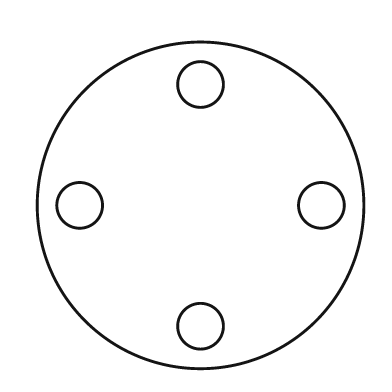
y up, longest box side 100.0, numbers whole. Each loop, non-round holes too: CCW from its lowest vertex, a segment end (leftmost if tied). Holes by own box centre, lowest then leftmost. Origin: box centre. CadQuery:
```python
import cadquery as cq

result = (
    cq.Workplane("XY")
    .moveTo(0.0, 0.0)
    .circle(50.0)
    .moveTo(0.0, -37.0)
    .circle(7.0)
    .moveTo(-37.0, 0.0)
    .circle(7.0)
    .moveTo(37.0, 0.0)
    .circle(7.0)
    .moveTo(0.0, 37.0)
    .circle(7.0)
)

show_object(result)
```